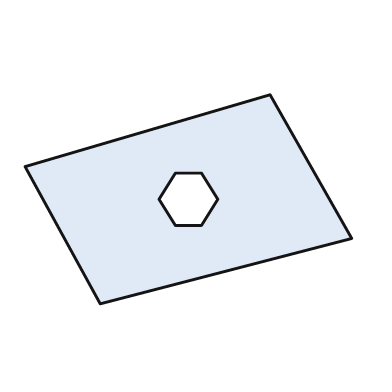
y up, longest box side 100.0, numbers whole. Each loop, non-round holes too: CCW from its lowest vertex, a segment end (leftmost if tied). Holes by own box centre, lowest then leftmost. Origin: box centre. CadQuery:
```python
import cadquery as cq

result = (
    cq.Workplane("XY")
    .moveTo(-27.0, -32.0)
    .lineTo(50.0, -12.0)
    .lineTo(25.0, 32.0)
    .lineTo(-50.0, 10.0)
    .close()
    .moveTo(-4.0, -8.0)
    .lineTo(4.0, -8.0)
    .lineTo(9.0, 0.0)
    .lineTo(4.0, 8.0)
    .lineTo(-4.0, 8.0)
    .lineTo(-9.0, 0.0)
    .close()
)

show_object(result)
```